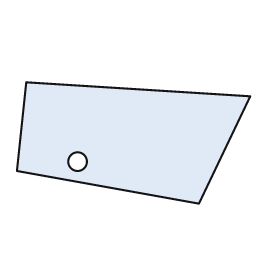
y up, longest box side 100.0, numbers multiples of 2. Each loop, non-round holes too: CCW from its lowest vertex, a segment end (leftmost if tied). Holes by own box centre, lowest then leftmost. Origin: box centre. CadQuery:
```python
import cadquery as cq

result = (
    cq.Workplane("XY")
    .moveTo(28.0, -26.0)
    .lineTo(50.0, 20.0)
    .lineTo(-46.0, 26.0)
    .lineTo(-50.0, -12.0)
    .close()
    .moveTo(-24.0, -8.0)
    .circle(4.0)
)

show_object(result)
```